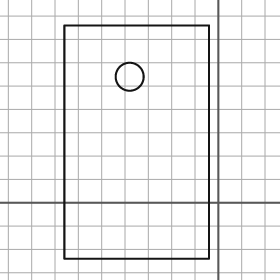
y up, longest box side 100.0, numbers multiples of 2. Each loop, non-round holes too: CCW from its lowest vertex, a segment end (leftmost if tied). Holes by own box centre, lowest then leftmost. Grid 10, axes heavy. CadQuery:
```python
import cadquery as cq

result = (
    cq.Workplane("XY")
    .moveTo(-66.0, -24.0)
    .lineTo(-4.0, -24.0)
    .lineTo(-4.0, 76.0)
    .lineTo(-66.0, 76.0)
    .close()
    .moveTo(-38.0, 54.0)
    .circle(6.0)
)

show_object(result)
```